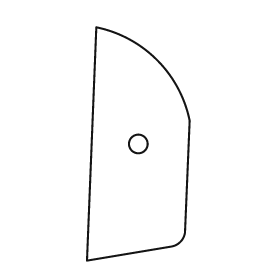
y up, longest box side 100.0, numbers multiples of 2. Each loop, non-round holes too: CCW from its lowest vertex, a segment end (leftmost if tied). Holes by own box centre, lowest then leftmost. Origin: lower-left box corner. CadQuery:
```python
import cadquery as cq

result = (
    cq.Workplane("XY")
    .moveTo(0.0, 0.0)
    .lineTo(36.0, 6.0)
    .threePointArc((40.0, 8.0), (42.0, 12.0))
    .lineTo(44.0, 60.0)
    .threePointArc((30.0, 86.0), (4.0, 100.0))
    .close()
    .moveTo(22.0, 50.0)
    .circle(4.0)
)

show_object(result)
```